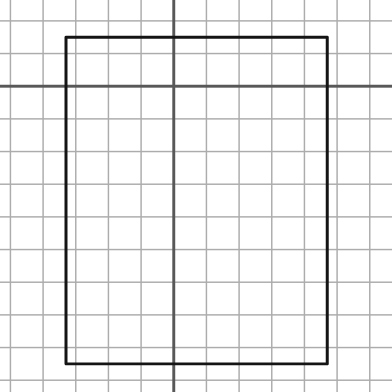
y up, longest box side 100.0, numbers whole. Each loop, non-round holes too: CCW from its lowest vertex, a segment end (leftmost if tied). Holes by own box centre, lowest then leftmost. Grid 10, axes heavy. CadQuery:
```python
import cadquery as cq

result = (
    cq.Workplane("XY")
    .moveTo(-33.0, -85.0)
    .lineTo(47.0, -85.0)
    .lineTo(47.0, 15.0)
    .lineTo(-33.0, 15.0)
    .close()
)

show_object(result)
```